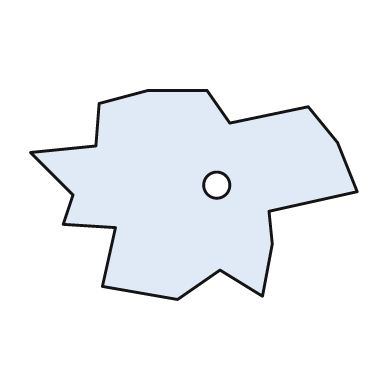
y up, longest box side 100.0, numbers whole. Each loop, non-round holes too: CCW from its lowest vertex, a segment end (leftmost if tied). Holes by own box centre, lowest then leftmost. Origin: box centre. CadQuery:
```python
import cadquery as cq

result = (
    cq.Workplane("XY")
    .moveTo(-5.0, -32.0)
    .lineTo(8.0, -23.0)
    .lineTo(21.0, -31.0)
    .lineTo(24.0, -15.0)
    .lineTo(23.0, -5.0)
    .lineTo(50.0, 1.0)
    .lineTo(44.0, 16.0)
    .lineTo(35.0, 27.0)
    .lineTo(11.0, 22.0)
    .lineTo(4.0, 32.0)
    .lineTo(-14.0, 32.0)
    .lineTo(-29.0, 28.0)
    .lineTo(-30.0, 15.0)
    .lineTo(-50.0, 13.0)
    .lineTo(-37.0, 0.0)
    .lineTo(-40.0, -9.0)
    .lineTo(-24.0, -10.0)
    .lineTo(-28.0, -28.0)
    .close()
    .moveTo(7.0, 3.0)
    .circle(4.0)
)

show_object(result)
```